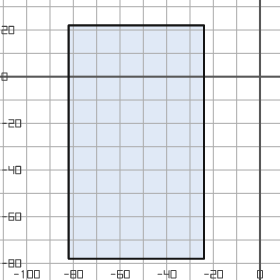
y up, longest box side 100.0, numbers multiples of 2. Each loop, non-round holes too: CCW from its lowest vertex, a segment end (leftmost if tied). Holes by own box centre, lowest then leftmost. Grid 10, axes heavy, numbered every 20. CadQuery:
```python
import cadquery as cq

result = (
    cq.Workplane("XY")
    .moveTo(-82.0, -78.0)
    .lineTo(-24.0, -78.0)
    .lineTo(-24.0, 22.0)
    .lineTo(-82.0, 22.0)
    .close()
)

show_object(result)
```